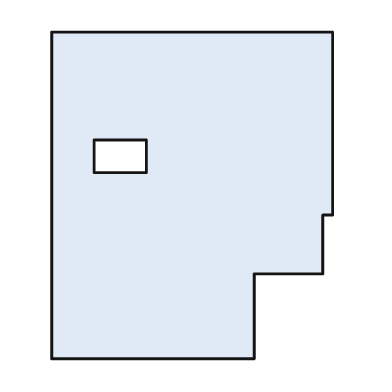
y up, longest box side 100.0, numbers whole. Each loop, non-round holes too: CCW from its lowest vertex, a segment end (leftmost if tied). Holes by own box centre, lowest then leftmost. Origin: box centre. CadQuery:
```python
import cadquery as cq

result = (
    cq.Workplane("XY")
    .moveTo(-43.0, -50.0)
    .lineTo(19.0, -50.0)
    .lineTo(19.0, -24.0)
    .lineTo(40.0, -24.0)
    .lineTo(40.0, -6.0)
    .lineTo(43.0, -6.0)
    .lineTo(43.0, 50.0)
    .lineTo(-43.0, 50.0)
    .close()
    .moveTo(-30.0, 7.0)
    .lineTo(-14.0, 7.0)
    .lineTo(-14.0, 17.0)
    .lineTo(-30.0, 17.0)
    .close()
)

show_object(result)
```